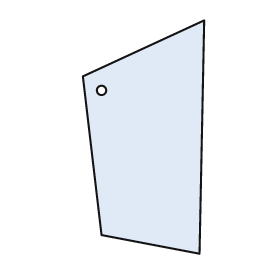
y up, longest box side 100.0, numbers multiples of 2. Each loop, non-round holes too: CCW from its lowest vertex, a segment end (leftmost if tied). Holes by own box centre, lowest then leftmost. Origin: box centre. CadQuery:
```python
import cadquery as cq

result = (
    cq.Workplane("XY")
    .moveTo(24.0, -50.0)
    .lineTo(26.0, 50.0)
    .lineTo(-26.0, 26.0)
    .lineTo(-18.0, -42.0)
    .close()
    .moveTo(-18.0, 20.0)
    .circle(2.0)
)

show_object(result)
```